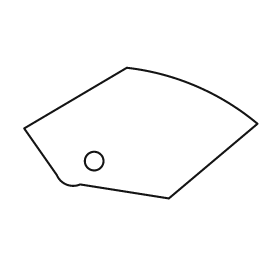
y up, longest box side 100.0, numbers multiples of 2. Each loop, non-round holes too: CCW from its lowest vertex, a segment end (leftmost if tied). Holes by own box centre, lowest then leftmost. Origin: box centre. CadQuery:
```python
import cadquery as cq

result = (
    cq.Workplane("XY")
    .moveTo(12.0, -28.0)
    .lineTo(50.0, 4.0)
    .threePointArc((24.0, 20.0), (-6.0, 28.0))
    .lineTo(-50.0, 2.0)
    .lineTo(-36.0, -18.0)
    .threePointArc((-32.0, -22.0), (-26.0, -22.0))
    .close()
    .moveTo(-20.0, -12.0)
    .circle(4.0)
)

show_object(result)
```